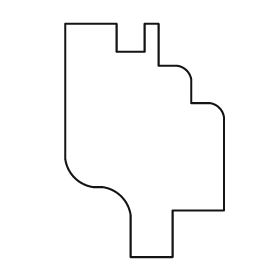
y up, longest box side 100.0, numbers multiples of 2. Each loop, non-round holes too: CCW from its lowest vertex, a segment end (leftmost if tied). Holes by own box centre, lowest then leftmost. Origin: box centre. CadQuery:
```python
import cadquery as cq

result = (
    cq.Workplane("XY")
    .moveTo(-6.0, -50.0)
    .lineTo(12.0, -50.0)
    .lineTo(12.0, -30.0)
    .lineTo(34.0, -30.0)
    .lineTo(34.0, 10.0)
    .threePointArc((32.0, 14.0), (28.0, 16.0))
    .lineTo(20.0, 16.0)
    .lineTo(20.0, 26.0)
    .threePointArc((18.0, 30.0), (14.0, 32.0))
    .lineTo(6.0, 32.0)
    .lineTo(6.0, 50.0)
    .lineTo(0.0, 50.0)
    .lineTo(0.0, 38.0)
    .lineTo(-12.0, 38.0)
    .lineTo(-12.0, 50.0)
    .lineTo(-34.0, 50.0)
    .lineTo(-34.0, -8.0)
    .threePointArc((-30.0, -16.0), (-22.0, -20.0))
    .lineTo(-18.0, -20.0)
    .threePointArc((-10.0, -24.0), (-6.0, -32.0))
    .close()
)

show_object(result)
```